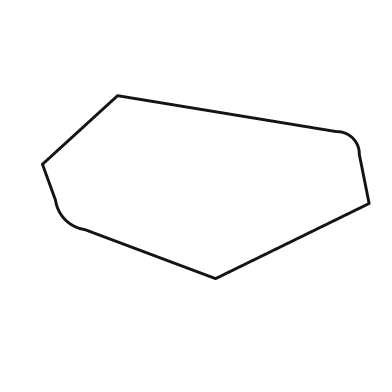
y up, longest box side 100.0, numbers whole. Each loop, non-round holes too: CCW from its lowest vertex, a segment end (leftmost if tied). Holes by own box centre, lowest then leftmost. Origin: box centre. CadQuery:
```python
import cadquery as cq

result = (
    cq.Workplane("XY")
    .moveTo(3.0, -28.0)
    .lineTo(50.0, -5.0)
    .lineTo(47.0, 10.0)
    .threePointArc((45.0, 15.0), (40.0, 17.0))
    .lineTo(-27.0, 28.0)
    .lineTo(-50.0, 7.0)
    .lineTo(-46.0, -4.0)
    .threePointArc((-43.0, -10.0), (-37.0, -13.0))
    .close()
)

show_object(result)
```